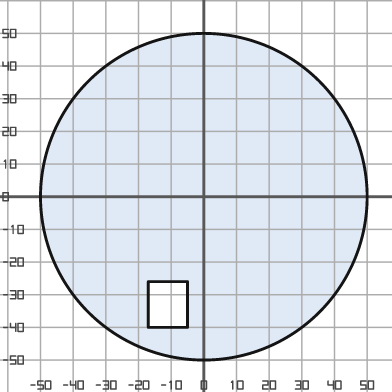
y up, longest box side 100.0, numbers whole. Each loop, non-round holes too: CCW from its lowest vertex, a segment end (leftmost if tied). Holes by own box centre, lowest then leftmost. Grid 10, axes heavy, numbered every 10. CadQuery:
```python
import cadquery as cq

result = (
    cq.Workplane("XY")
    .moveTo(0.0, 0.0)
    .circle(50.0)
    .moveTo(-17.0, -40.0)
    .lineTo(-5.0, -40.0)
    .lineTo(-5.0, -26.0)
    .lineTo(-17.0, -26.0)
    .close()
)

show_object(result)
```